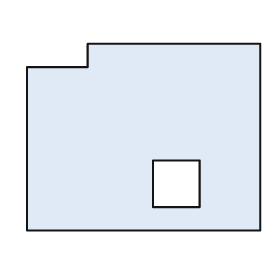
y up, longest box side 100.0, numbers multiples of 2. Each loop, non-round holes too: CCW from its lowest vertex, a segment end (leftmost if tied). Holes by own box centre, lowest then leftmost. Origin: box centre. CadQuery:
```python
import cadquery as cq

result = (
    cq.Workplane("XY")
    .moveTo(-50.0, -40.0)
    .lineTo(50.0, -40.0)
    .lineTo(50.0, 40.0)
    .lineTo(-24.0, 40.0)
    .lineTo(-24.0, 30.0)
    .lineTo(-50.0, 30.0)
    .close()
    .moveTo(4.0, -30.0)
    .lineTo(24.0, -30.0)
    .lineTo(24.0, -10.0)
    .lineTo(4.0, -10.0)
    .close()
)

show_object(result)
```